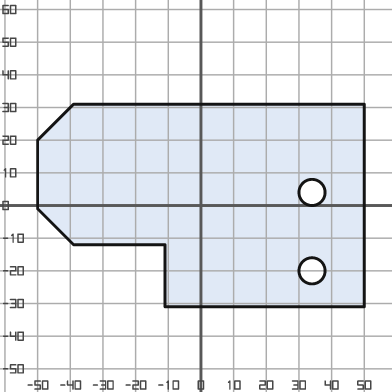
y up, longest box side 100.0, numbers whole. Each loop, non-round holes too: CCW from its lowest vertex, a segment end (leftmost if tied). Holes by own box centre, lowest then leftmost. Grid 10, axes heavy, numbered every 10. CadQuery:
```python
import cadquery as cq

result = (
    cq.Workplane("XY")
    .moveTo(-11.0, -31.0)
    .lineTo(50.0, -31.0)
    .lineTo(50.0, 31.0)
    .lineTo(-39.0, 31.0)
    .lineTo(-50.0, 20.0)
    .lineTo(-50.0, -1.0)
    .lineTo(-39.0, -12.0)
    .lineTo(-11.0, -12.0)
    .close()
    .moveTo(34.0, -20.0)
    .circle(4.0)
    .moveTo(34.0, 4.0)
    .circle(4.0)
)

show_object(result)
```